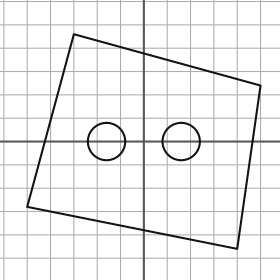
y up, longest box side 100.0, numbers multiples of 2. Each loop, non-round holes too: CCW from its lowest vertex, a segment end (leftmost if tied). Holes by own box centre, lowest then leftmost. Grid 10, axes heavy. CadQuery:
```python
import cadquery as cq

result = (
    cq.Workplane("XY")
    .moveTo(40.0, -46.0)
    .lineTo(50.0, 24.0)
    .lineTo(-30.0, 46.0)
    .lineTo(-50.0, -28.0)
    .close()
    .moveTo(-16.0, 0.0)
    .circle(8.0)
    .moveTo(16.0, 0.0)
    .circle(8.0)
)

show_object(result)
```